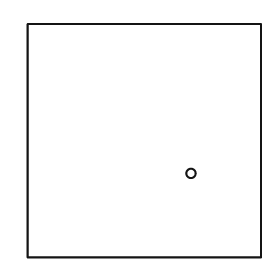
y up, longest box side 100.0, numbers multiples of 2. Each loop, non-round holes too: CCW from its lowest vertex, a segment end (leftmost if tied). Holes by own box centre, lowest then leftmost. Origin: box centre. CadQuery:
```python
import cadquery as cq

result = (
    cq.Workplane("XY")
    .moveTo(-50.0, -50.0)
    .lineTo(50.0, -50.0)
    .lineTo(50.0, 50.0)
    .lineTo(-50.0, 50.0)
    .close()
    .moveTo(20.0, -14.0)
    .circle(2.0)
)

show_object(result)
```